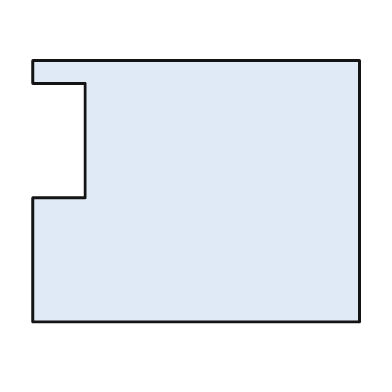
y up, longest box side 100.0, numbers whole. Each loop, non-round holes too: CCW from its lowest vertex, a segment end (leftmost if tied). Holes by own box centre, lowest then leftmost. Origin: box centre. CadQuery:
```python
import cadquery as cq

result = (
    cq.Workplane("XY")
    .moveTo(-50.0, -40.0)
    .lineTo(50.0, -40.0)
    .lineTo(50.0, 40.0)
    .lineTo(-50.0, 40.0)
    .lineTo(-50.0, 33.0)
    .lineTo(-34.0, 33.0)
    .lineTo(-34.0, -2.0)
    .lineTo(-50.0, -2.0)
    .close()
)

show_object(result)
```